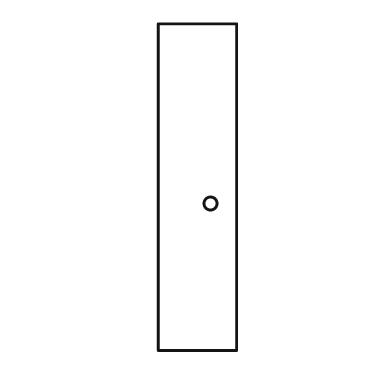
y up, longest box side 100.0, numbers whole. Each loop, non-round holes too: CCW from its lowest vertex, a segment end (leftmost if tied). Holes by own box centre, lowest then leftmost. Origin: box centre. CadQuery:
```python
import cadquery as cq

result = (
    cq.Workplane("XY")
    .moveTo(-12.0, -50.0)
    .lineTo(12.0, -50.0)
    .lineTo(12.0, 50.0)
    .lineTo(-12.0, 50.0)
    .close()
    .moveTo(4.0, -5.0)
    .circle(2.0)
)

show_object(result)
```